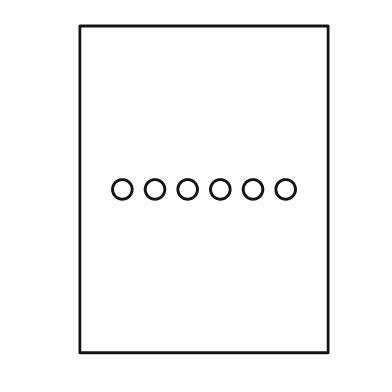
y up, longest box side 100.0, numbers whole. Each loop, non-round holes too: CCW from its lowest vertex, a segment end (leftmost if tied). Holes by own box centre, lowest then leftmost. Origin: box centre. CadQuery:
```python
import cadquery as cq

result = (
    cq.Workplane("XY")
    .moveTo(-38.0, -50.0)
    .lineTo(38.0, -50.0)
    .lineTo(38.0, 50.0)
    .lineTo(-38.0, 50.0)
    .close()
    .moveTo(-25.0, 0.0)
    .circle(3.0)
    .moveTo(-15.0, 0.0)
    .circle(3.0)
    .moveTo(-5.0, 0.0)
    .circle(3.0)
    .moveTo(5.0, 0.0)
    .circle(3.0)
    .moveTo(15.0, 0.0)
    .circle(3.0)
    .moveTo(25.0, 0.0)
    .circle(3.0)
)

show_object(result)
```